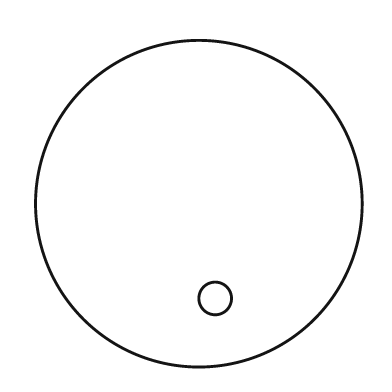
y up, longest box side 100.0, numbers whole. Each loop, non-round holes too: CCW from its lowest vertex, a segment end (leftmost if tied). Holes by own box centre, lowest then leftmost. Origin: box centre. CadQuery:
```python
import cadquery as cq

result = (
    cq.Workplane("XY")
    .moveTo(0.0, 0.0)
    .circle(50.0)
    .moveTo(5.0, -29.0)
    .circle(5.0)
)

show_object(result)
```